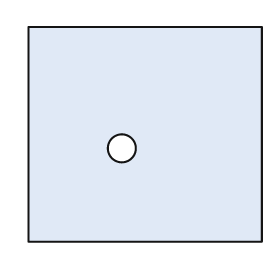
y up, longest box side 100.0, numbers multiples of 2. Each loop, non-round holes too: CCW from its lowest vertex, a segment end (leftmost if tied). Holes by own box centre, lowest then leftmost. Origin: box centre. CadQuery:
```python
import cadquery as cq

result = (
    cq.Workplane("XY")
    .moveTo(-50.0, -46.0)
    .lineTo(50.0, -46.0)
    .lineTo(50.0, 46.0)
    .lineTo(-50.0, 46.0)
    .close()
    .moveTo(-10.0, -6.0)
    .circle(6.0)
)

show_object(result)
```